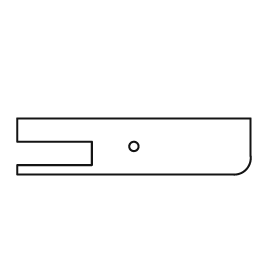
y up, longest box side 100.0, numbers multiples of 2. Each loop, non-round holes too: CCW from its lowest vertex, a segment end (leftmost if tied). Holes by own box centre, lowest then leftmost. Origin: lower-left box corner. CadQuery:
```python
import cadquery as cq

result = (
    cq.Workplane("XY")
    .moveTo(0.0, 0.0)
    .lineTo(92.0, 0.0)
    .threePointArc((98.0, 2.0), (100.0, 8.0))
    .lineTo(100.0, 24.0)
    .lineTo(0.0, 24.0)
    .lineTo(0.0, 14.0)
    .lineTo(32.0, 14.0)
    .lineTo(32.0, 4.0)
    .lineTo(0.0, 4.0)
    .close()
    .moveTo(50.0, 12.0)
    .circle(2.0)
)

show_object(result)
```